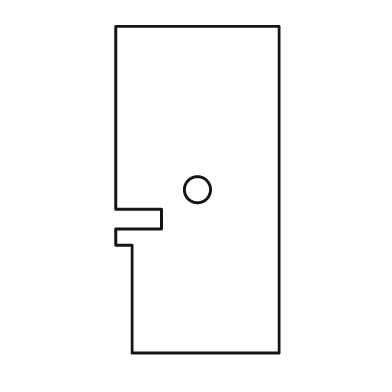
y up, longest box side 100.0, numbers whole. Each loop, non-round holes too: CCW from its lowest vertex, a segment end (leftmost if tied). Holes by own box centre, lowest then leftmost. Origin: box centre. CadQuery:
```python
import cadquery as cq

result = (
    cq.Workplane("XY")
    .moveTo(-20.0, -50.0)
    .lineTo(25.0, -50.0)
    .lineTo(25.0, 50.0)
    .lineTo(-25.0, 50.0)
    .lineTo(-25.0, -6.0)
    .lineTo(-11.0, -6.0)
    .lineTo(-11.0, -12.0)
    .lineTo(-25.0, -12.0)
    .lineTo(-25.0, -17.0)
    .lineTo(-20.0, -17.0)
    .close()
    .moveTo(0.0, 0.0)
    .circle(4.0)
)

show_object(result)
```